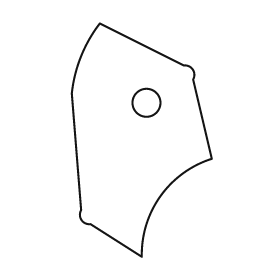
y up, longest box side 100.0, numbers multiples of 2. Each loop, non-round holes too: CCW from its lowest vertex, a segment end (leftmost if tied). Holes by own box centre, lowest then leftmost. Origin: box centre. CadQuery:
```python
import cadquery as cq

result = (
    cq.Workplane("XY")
    .moveTo(0.0, -50.0)
    .threePointArc((8.0, -24.0), (30.0, -8.0))
    .lineTo(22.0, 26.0)
    .threePointArc((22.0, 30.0), (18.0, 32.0))
    .lineTo(-18.0, 50.0)
    .threePointArc((-26.0, 36.0), (-30.0, 20.0))
    .lineTo(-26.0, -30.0)
    .threePointArc((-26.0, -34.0), (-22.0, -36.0))
    .close()
    .moveTo(2.0, 16.0)
    .circle(6.0)
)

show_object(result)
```